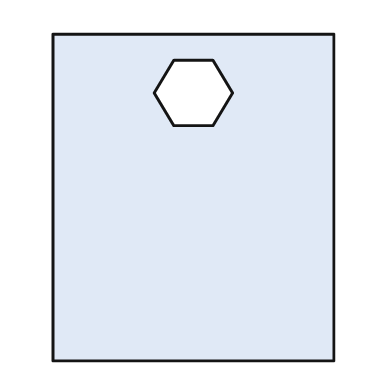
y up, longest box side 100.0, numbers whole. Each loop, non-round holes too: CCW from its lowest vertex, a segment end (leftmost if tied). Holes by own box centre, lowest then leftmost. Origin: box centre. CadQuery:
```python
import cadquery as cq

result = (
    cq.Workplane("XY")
    .moveTo(-43.0, -50.0)
    .lineTo(43.0, -50.0)
    .lineTo(43.0, 50.0)
    .lineTo(-43.0, 50.0)
    .close()
    .moveTo(-6.0, 22.0)
    .lineTo(6.0, 22.0)
    .lineTo(12.0, 32.0)
    .lineTo(6.0, 42.0)
    .lineTo(-6.0, 42.0)
    .lineTo(-12.0, 32.0)
    .close()
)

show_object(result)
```